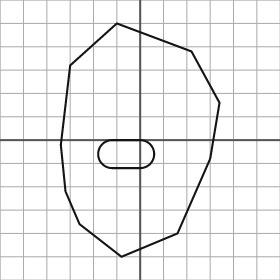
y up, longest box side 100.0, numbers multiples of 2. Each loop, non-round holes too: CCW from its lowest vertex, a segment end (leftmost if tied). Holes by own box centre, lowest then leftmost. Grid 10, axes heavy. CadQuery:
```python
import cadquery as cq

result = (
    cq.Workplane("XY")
    .moveTo(-8.0, -50.0)
    .lineTo(16.0, -40.0)
    .lineTo(30.0, -8.0)
    .lineTo(34.0, 16.0)
    .lineTo(22.0, 38.0)
    .lineTo(-10.0, 50.0)
    .lineTo(-30.0, 32.0)
    .lineTo(-34.0, -2.0)
    .lineTo(-32.0, -22.0)
    .lineTo(-26.0, -36.0)
    .close()
    .moveTo(-12.0, -12.0)
    .lineTo(0.0, -12.0)
    .threePointArc((6.0, -6.0), (0.0, 0.0))
    .lineTo(-12.0, 0.0)
    .threePointArc((-18.0, -6.0), (-12.0, -12.0))
    .close()
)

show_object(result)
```